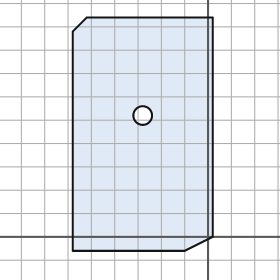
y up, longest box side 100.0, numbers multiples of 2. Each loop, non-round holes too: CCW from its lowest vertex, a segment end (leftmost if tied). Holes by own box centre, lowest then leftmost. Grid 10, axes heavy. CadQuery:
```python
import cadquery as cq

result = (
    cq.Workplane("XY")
    .moveTo(-58.0, -6.0)
    .lineTo(-10.0, -6.0)
    .lineTo(2.0, 0.0)
    .lineTo(2.0, 94.0)
    .lineTo(-52.0, 94.0)
    .lineTo(-58.0, 88.0)
    .close()
    .moveTo(-28.0, 52.0)
    .circle(4.0)
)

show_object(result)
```